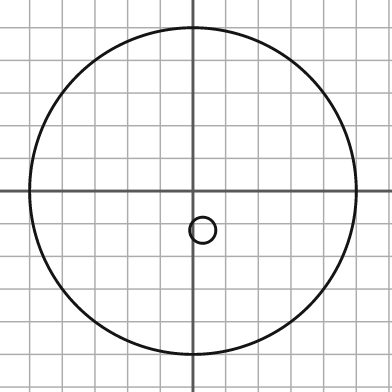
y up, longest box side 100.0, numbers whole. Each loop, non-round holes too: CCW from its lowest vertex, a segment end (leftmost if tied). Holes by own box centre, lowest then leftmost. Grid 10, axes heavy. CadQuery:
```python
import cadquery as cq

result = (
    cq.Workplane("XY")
    .moveTo(0.0, 0.0)
    .circle(50.0)
    .moveTo(3.0, -12.0)
    .circle(4.0)
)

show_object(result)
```